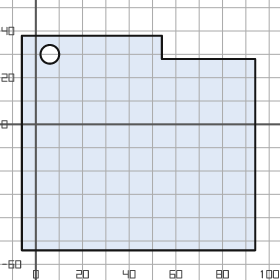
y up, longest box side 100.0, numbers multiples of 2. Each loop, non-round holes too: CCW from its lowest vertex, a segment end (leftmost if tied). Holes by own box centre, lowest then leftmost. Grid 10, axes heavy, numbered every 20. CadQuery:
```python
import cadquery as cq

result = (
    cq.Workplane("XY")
    .moveTo(-6.0, -54.0)
    .lineTo(94.0, -54.0)
    .lineTo(94.0, 28.0)
    .lineTo(54.0, 28.0)
    .lineTo(54.0, 38.0)
    .lineTo(-6.0, 38.0)
    .close()
    .moveTo(6.0, 30.0)
    .circle(4.0)
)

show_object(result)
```